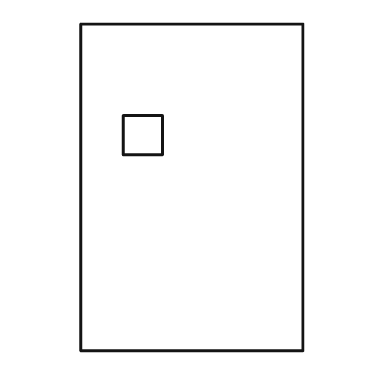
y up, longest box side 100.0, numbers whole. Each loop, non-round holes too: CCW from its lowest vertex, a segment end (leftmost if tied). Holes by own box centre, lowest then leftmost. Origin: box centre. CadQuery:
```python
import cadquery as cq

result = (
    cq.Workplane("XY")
    .moveTo(-34.0, -50.0)
    .lineTo(34.0, -50.0)
    .lineTo(34.0, 50.0)
    .lineTo(-34.0, 50.0)
    .close()
    .moveTo(-21.0, 10.0)
    .lineTo(-9.0, 10.0)
    .lineTo(-9.0, 22.0)
    .lineTo(-21.0, 22.0)
    .close()
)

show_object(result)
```